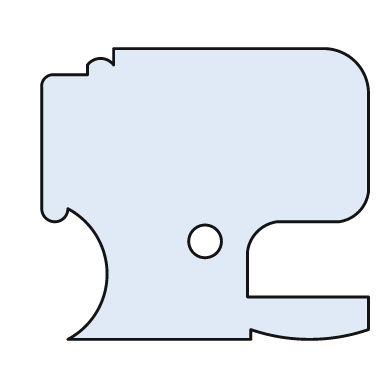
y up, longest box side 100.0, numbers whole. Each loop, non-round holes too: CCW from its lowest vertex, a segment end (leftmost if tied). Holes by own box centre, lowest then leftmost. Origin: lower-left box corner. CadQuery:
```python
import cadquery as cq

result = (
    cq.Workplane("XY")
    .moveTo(8.0, 0.0)
    .lineTo(64.0, 0.0)
    .lineTo(64.0, 3.0)
    .threePointArc((82.0, 0.0), (100.0, 3.0))
    .lineTo(100.0, 13.0)
    .lineTo(63.0, 13.0)
    .lineTo(63.0, 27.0)
    .threePointArc((66.0, 33.0), (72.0, 36.0))
    .lineTo(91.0, 36.0)
    .threePointArc((97.0, 39.0), (100.0, 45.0))
    .lineTo(100.0, 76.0)
    .threePointArc((96.0, 85.0), (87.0, 89.0))
    .lineTo(22.0, 89.0)
    .lineTo(22.0, 84.0)
    .threePointArc((18.0, 86.0), (14.0, 84.0))
    .lineTo(14.0, 81.0)
    .lineTo(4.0, 81.0)
    .threePointArc((1.0, 80.0), (0.0, 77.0))
    .lineTo(0.0, 40.0)
    .threePointArc((4.0, 36.0), (8.0, 40.0))
    .threePointArc((20.0, 20.0), (8.0, 0.0))
    .close()
    .moveTo(50.0, 30.0)
    .circle(5.0)
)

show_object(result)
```